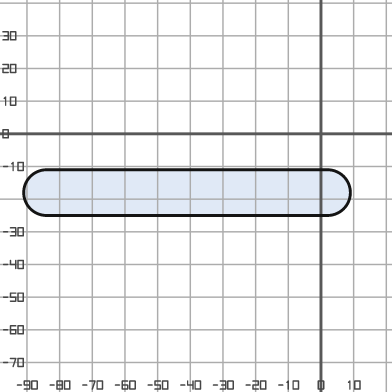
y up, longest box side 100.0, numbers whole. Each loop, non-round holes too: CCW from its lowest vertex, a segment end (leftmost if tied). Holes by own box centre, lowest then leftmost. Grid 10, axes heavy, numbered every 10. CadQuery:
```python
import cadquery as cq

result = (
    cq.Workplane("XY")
    .moveTo(-84.0, -25.0)
    .lineTo(2.0, -25.0)
    .threePointArc((9.0, -18.0), (2.0, -11.0))
    .lineTo(-84.0, -11.0)
    .threePointArc((-91.0, -18.0), (-84.0, -25.0))
    .close()
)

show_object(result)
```